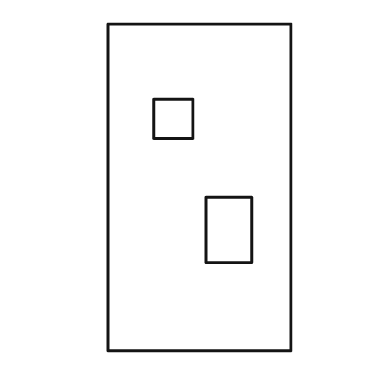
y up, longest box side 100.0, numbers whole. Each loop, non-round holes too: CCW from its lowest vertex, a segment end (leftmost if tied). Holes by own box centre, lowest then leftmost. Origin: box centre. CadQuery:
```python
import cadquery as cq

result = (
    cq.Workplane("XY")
    .moveTo(-28.0, -50.0)
    .lineTo(28.0, -50.0)
    .lineTo(28.0, 50.0)
    .lineTo(-28.0, 50.0)
    .close()
    .moveTo(2.0, -23.0)
    .lineTo(16.0, -23.0)
    .lineTo(16.0, -3.0)
    .lineTo(2.0, -3.0)
    .close()
    .moveTo(-14.0, 15.0)
    .lineTo(-2.0, 15.0)
    .lineTo(-2.0, 27.0)
    .lineTo(-14.0, 27.0)
    .close()
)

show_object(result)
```